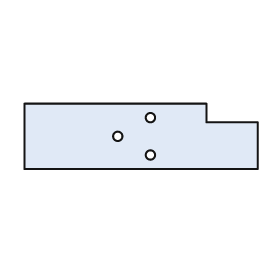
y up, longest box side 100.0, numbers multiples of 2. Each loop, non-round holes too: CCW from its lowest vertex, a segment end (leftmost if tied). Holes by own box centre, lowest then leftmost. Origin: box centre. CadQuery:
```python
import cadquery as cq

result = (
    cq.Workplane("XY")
    .moveTo(-50.0, -14.0)
    .lineTo(50.0, -14.0)
    .lineTo(50.0, 6.0)
    .lineTo(28.0, 6.0)
    .lineTo(28.0, 14.0)
    .lineTo(-50.0, 14.0)
    .close()
    .moveTo(4.0, -8.0)
    .circle(2.0)
    .moveTo(-10.0, 0.0)
    .circle(2.0)
    .moveTo(4.0, 8.0)
    .circle(2.0)
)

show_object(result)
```